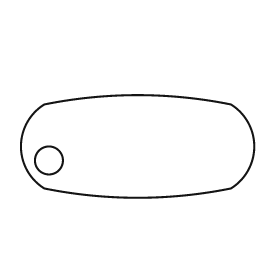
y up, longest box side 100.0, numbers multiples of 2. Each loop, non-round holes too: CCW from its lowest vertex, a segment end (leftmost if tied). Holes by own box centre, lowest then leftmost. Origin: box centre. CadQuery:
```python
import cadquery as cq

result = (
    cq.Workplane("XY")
    .moveTo(-40.0, -18.0)
    .threePointArc((0.0, -22.0), (40.0, -18.0))
    .threePointArc((50.0, 0.0), (40.0, 18.0))
    .threePointArc((0.0, 22.0), (-40.0, 18.0))
    .threePointArc((-50.0, 0.0), (-40.0, -18.0))
    .close()
    .moveTo(-38.0, -6.0)
    .circle(6.0)
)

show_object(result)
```